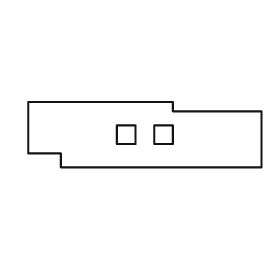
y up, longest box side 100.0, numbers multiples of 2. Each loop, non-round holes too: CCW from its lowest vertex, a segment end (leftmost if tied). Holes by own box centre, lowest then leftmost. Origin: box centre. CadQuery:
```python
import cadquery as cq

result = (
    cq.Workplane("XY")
    .moveTo(-36.0, -14.0)
    .lineTo(50.0, -14.0)
    .lineTo(50.0, 10.0)
    .lineTo(12.0, 10.0)
    .lineTo(12.0, 14.0)
    .lineTo(-50.0, 14.0)
    .lineTo(-50.0, -8.0)
    .lineTo(-36.0, -8.0)
    .close()
    .moveTo(-12.0, -4.0)
    .lineTo(-4.0, -4.0)
    .lineTo(-4.0, 4.0)
    .lineTo(-12.0, 4.0)
    .close()
    .moveTo(4.0, -4.0)
    .lineTo(12.0, -4.0)
    .lineTo(12.0, 4.0)
    .lineTo(4.0, 4.0)
    .close()
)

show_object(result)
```